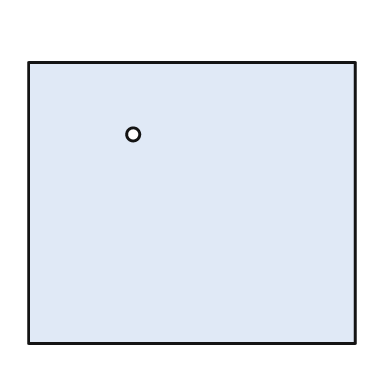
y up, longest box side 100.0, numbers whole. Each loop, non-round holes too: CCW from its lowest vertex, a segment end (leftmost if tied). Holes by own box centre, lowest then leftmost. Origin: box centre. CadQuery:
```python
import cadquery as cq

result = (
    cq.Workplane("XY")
    .moveTo(-50.0, -43.0)
    .lineTo(50.0, -43.0)
    .lineTo(50.0, 43.0)
    .lineTo(-50.0, 43.0)
    .close()
    .moveTo(-18.0, 21.0)
    .circle(2.0)
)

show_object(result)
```